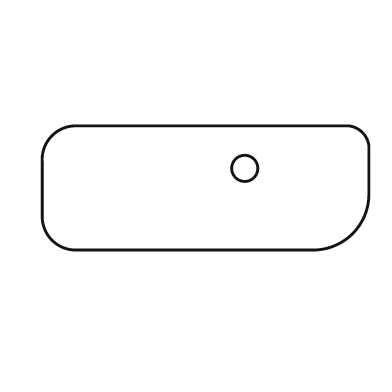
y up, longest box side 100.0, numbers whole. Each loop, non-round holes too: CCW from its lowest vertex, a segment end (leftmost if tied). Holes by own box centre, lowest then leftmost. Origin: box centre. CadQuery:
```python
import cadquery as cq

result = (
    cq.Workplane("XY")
    .moveTo(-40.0, -19.0)
    .lineTo(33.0, -19.0)
    .threePointArc((45.0, -14.0), (50.0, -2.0))
    .lineTo(50.0, 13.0)
    .threePointArc((48.0, 17.0), (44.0, 19.0))
    .lineTo(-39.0, 19.0)
    .threePointArc((-47.0, 16.0), (-50.0, 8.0))
    .lineTo(-50.0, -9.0)
    .threePointArc((-47.0, -16.0), (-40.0, -19.0))
    .close()
    .moveTo(12.0, 6.0)
    .circle(4.0)
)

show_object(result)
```